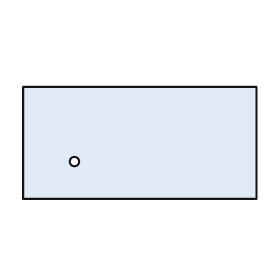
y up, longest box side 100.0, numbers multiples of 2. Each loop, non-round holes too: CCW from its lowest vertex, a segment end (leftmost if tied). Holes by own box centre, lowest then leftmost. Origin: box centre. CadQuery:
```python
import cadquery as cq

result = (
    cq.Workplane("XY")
    .moveTo(-50.0, -24.0)
    .lineTo(50.0, -24.0)
    .lineTo(50.0, 24.0)
    .lineTo(-50.0, 24.0)
    .close()
    .moveTo(-28.0, -8.0)
    .circle(2.0)
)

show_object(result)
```